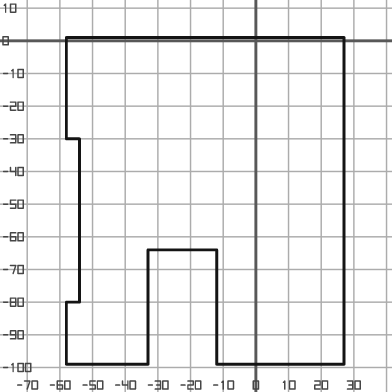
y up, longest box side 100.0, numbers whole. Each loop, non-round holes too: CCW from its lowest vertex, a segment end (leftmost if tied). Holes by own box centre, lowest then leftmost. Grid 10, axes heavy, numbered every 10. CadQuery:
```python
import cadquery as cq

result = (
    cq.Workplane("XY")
    .moveTo(-58.0, -99.0)
    .lineTo(-33.0, -99.0)
    .lineTo(-33.0, -64.0)
    .lineTo(-12.0, -64.0)
    .lineTo(-12.0, -99.0)
    .lineTo(27.0, -99.0)
    .lineTo(27.0, 1.0)
    .lineTo(-58.0, 1.0)
    .lineTo(-58.0, -30.0)
    .lineTo(-54.0, -30.0)
    .lineTo(-54.0, -80.0)
    .lineTo(-58.0, -80.0)
    .close()
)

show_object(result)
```